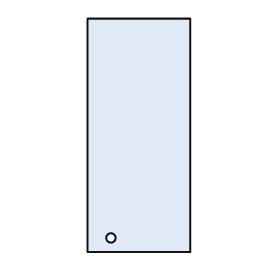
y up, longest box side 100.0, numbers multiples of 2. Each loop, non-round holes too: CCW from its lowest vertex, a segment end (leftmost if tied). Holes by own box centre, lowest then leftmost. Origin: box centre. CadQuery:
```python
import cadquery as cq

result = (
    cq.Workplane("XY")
    .moveTo(-22.0, -50.0)
    .lineTo(22.0, -50.0)
    .lineTo(22.0, 50.0)
    .lineTo(-22.0, 50.0)
    .close()
    .moveTo(-12.0, -44.0)
    .circle(2.0)
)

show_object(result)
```